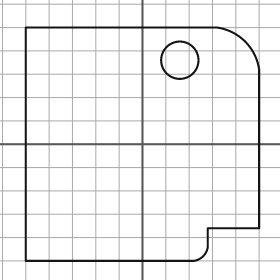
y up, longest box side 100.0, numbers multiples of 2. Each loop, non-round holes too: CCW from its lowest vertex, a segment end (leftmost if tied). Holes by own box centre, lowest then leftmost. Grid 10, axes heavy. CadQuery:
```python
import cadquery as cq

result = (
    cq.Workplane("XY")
    .moveTo(-50.0, -50.0)
    .lineTo(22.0, -50.0)
    .threePointArc((26.0, -48.0), (28.0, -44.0))
    .lineTo(28.0, -36.0)
    .lineTo(50.0, -36.0)
    .lineTo(50.0, 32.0)
    .threePointArc((44.0, 44.0), (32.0, 50.0))
    .lineTo(-50.0, 50.0)
    .close()
    .moveTo(16.0, 36.0)
    .circle(8.0)
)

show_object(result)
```